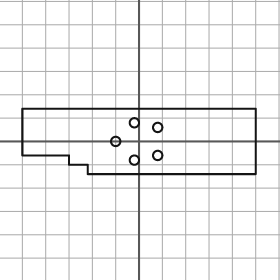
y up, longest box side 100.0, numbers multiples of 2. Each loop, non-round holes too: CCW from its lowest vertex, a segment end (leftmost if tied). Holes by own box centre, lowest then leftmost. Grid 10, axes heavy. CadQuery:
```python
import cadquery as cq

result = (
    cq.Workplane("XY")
    .moveTo(-22.0, -14.0)
    .lineTo(50.0, -14.0)
    .lineTo(50.0, 14.0)
    .lineTo(-50.0, 14.0)
    .lineTo(-50.0, -6.0)
    .lineTo(-30.0, -6.0)
    .lineTo(-30.0, -10.0)
    .lineTo(-22.0, -10.0)
    .close()
    .moveTo(-2.0, -8.0)
    .circle(2.0)
    .moveTo(8.0, -6.0)
    .circle(2.0)
    .moveTo(-10.0, 0.0)
    .circle(2.0)
    .moveTo(8.0, 6.0)
    .circle(2.0)
    .moveTo(-2.0, 8.0)
    .circle(2.0)
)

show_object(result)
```